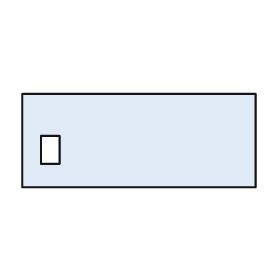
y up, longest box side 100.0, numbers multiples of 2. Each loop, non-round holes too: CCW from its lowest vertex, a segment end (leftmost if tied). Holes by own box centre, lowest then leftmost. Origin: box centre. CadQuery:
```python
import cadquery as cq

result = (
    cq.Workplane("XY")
    .moveTo(-50.0, -20.0)
    .lineTo(50.0, -20.0)
    .lineTo(50.0, 20.0)
    .lineTo(-50.0, 20.0)
    .close()
    .moveTo(-42.0, -10.0)
    .lineTo(-34.0, -10.0)
    .lineTo(-34.0, 2.0)
    .lineTo(-42.0, 2.0)
    .close()
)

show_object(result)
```